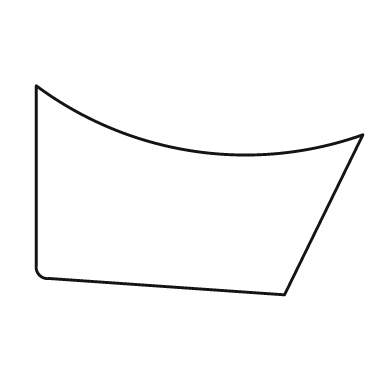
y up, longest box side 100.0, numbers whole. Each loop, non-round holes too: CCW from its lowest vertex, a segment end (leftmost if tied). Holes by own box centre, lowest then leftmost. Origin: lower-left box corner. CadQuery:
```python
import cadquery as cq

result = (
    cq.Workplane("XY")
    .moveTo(76.0, 0.0)
    .lineTo(100.0, 49.0)
    .threePointArc((48.0, 44.0), (0.0, 64.0))
    .lineTo(0.0, 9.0)
    .threePointArc((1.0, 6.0), (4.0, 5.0))
    .close()
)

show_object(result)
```